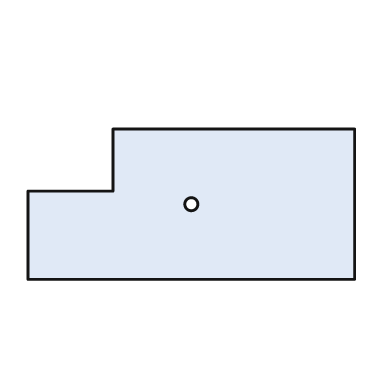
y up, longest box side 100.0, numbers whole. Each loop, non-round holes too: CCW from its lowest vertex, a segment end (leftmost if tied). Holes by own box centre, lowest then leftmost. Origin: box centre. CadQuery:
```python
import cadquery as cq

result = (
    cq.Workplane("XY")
    .moveTo(-50.0, -23.0)
    .lineTo(50.0, -23.0)
    .lineTo(50.0, 23.0)
    .lineTo(-24.0, 23.0)
    .lineTo(-24.0, 4.0)
    .lineTo(-50.0, 4.0)
    .close()
    .moveTo(0.0, 0.0)
    .circle(2.0)
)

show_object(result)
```